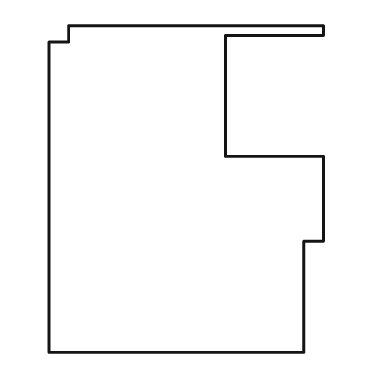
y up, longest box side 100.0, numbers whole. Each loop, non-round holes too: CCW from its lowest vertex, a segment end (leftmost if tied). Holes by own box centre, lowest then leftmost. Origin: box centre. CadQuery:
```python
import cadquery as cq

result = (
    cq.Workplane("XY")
    .moveTo(-42.0, -50.0)
    .lineTo(36.0, -50.0)
    .lineTo(36.0, -16.0)
    .lineTo(42.0, -16.0)
    .lineTo(42.0, 10.0)
    .lineTo(12.0, 10.0)
    .lineTo(12.0, 47.0)
    .lineTo(42.0, 47.0)
    .lineTo(42.0, 50.0)
    .lineTo(-36.0, 50.0)
    .lineTo(-36.0, 45.0)
    .lineTo(-42.0, 45.0)
    .close()
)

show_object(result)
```